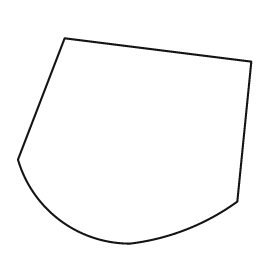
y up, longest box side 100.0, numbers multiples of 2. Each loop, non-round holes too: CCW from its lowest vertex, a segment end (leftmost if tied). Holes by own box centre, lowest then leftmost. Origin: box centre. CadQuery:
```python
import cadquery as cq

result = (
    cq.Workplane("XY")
    .moveTo(-2.0, -44.0)
    .threePointArc((22.0, -38.0), (44.0, -26.0))
    .lineTo(50.0, 34.0)
    .lineTo(-30.0, 44.0)
    .lineTo(-50.0, -8.0)
    .threePointArc((-32.0, -34.0), (-2.0, -44.0))
    .close()
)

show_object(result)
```